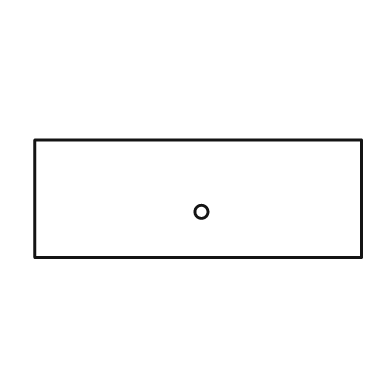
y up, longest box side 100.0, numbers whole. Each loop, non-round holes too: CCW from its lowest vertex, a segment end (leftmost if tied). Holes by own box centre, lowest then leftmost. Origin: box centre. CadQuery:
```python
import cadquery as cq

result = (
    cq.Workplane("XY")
    .moveTo(-50.0, -18.0)
    .lineTo(50.0, -18.0)
    .lineTo(50.0, 18.0)
    .lineTo(-50.0, 18.0)
    .close()
    .moveTo(1.0, -4.0)
    .circle(2.0)
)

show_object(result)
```